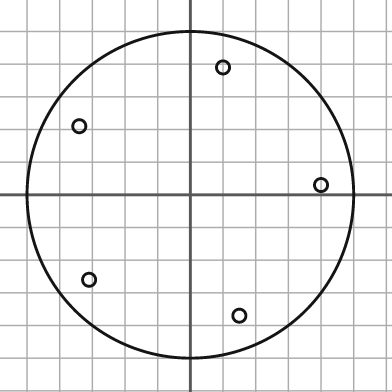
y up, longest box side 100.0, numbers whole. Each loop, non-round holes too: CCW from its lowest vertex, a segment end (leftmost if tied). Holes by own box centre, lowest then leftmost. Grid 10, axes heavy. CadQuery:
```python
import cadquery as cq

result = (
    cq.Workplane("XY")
    .moveTo(0.0, 0.0)
    .circle(50.0)
    .moveTo(15.0, -37.0)
    .circle(2.0)
    .moveTo(-31.0, -26.0)
    .circle(2.0)
    .moveTo(40.0, 3.0)
    .circle(2.0)
    .moveTo(-34.0, 21.0)
    .circle(2.0)
    .moveTo(10.0, 39.0)
    .circle(2.0)
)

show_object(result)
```